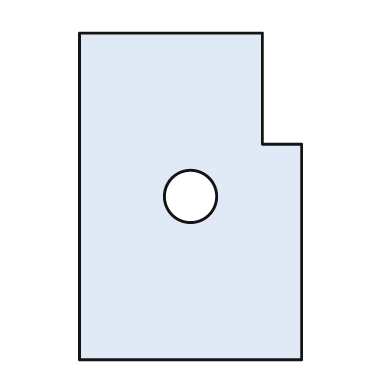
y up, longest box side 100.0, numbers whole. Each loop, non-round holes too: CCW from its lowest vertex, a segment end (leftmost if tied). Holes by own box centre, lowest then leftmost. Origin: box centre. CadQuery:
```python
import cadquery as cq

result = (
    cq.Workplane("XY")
    .moveTo(-34.0, -50.0)
    .lineTo(34.0, -50.0)
    .lineTo(34.0, 16.0)
    .lineTo(22.0, 16.0)
    .lineTo(22.0, 50.0)
    .lineTo(-34.0, 50.0)
    .close()
    .moveTo(0.0, 0.0)
    .circle(8.0)
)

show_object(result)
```